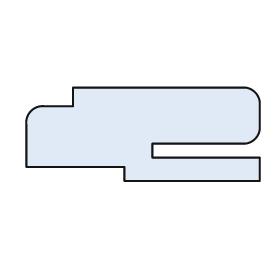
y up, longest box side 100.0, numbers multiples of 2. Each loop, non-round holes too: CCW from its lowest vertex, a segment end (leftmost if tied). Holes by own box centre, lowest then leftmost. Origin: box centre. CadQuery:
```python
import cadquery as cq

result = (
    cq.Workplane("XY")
    .moveTo(-8.0, -20.0)
    .lineTo(50.0, -20.0)
    .lineTo(50.0, -10.0)
    .lineTo(4.0, -10.0)
    .lineTo(4.0, -4.0)
    .lineTo(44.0, -4.0)
    .threePointArc((48.0, -2.0), (50.0, 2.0))
    .lineTo(50.0, 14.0)
    .threePointArc((48.0, 18.0), (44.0, 20.0))
    .lineTo(-30.0, 20.0)
    .lineTo(-30.0, 12.0)
    .lineTo(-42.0, 12.0)
    .threePointArc((-48.0, 10.0), (-50.0, 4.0))
    .lineTo(-50.0, -14.0)
    .lineTo(-8.0, -14.0)
    .close()
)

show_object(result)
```